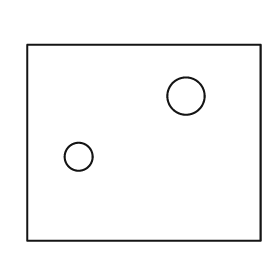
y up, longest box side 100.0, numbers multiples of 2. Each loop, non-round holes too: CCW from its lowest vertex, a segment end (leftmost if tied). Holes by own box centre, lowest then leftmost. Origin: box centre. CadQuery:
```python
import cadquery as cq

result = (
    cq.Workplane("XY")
    .moveTo(-50.0, -42.0)
    .lineTo(50.0, -42.0)
    .lineTo(50.0, 42.0)
    .lineTo(-50.0, 42.0)
    .close()
    .moveTo(-28.0, -6.0)
    .circle(6.0)
    .moveTo(18.0, 20.0)
    .circle(8.0)
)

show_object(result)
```